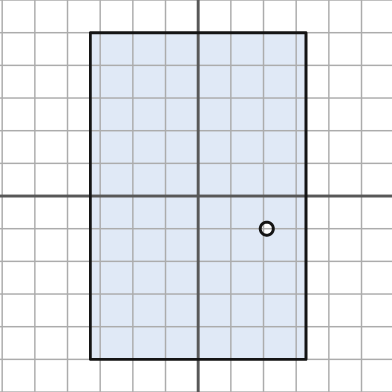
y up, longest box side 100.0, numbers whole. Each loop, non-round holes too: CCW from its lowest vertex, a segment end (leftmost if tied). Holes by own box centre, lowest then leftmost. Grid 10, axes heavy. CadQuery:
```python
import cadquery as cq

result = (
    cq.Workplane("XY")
    .moveTo(-33.0, -50.0)
    .lineTo(33.0, -50.0)
    .lineTo(33.0, 50.0)
    .lineTo(-33.0, 50.0)
    .close()
    .moveTo(21.0, -10.0)
    .circle(2.0)
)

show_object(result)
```